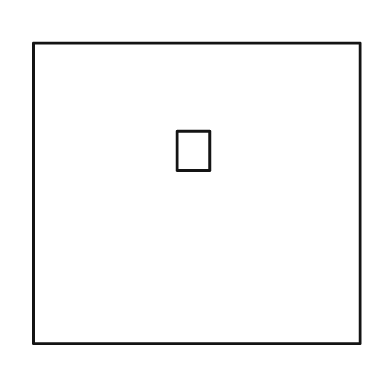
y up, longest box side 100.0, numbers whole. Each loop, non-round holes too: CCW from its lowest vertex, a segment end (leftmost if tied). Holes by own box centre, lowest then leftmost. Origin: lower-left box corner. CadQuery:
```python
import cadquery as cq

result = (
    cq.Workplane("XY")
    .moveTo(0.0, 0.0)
    .lineTo(100.0, 0.0)
    .lineTo(100.0, 92.0)
    .lineTo(0.0, 92.0)
    .close()
    .moveTo(44.0, 53.0)
    .lineTo(54.0, 53.0)
    .lineTo(54.0, 65.0)
    .lineTo(44.0, 65.0)
    .close()
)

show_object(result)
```